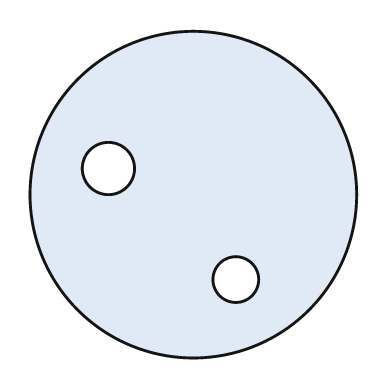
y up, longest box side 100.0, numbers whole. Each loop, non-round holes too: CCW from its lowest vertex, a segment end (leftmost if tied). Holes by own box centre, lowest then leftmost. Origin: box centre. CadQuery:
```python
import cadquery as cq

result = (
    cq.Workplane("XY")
    .moveTo(0.0, 0.0)
    .circle(50.0)
    .moveTo(13.0, -26.0)
    .circle(7.0)
    .moveTo(-26.0, 8.0)
    .circle(8.0)
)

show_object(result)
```